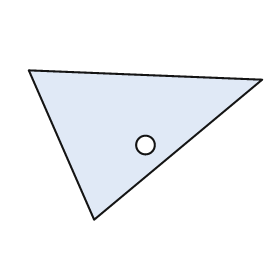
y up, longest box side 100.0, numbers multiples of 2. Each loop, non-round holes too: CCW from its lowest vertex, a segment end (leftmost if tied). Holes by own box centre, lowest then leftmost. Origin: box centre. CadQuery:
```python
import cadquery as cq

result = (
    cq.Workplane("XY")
    .moveTo(-22.0, -32.0)
    .lineTo(50.0, 28.0)
    .lineTo(-50.0, 32.0)
    .close()
    .moveTo(0.0, 0.0)
    .circle(4.0)
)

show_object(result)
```